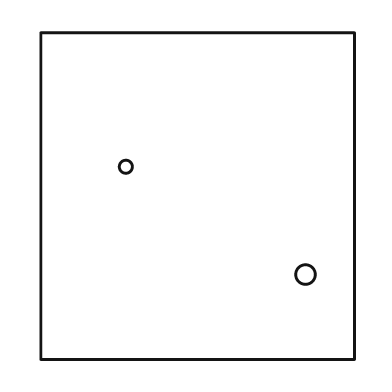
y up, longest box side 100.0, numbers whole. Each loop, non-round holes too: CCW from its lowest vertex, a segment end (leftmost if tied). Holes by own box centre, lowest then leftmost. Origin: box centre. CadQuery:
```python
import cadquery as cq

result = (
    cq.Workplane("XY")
    .moveTo(-48.0, -50.0)
    .lineTo(48.0, -50.0)
    .lineTo(48.0, 50.0)
    .lineTo(-48.0, 50.0)
    .close()
    .moveTo(33.0, -24.0)
    .circle(3.0)
    .moveTo(-22.0, 9.0)
    .circle(2.0)
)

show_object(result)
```